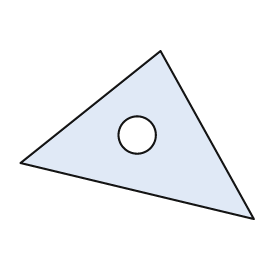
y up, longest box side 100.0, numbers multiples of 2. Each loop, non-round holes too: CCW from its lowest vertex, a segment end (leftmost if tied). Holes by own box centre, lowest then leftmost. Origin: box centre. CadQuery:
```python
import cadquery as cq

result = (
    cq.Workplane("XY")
    .moveTo(50.0, -36.0)
    .lineTo(10.0, 36.0)
    .lineTo(-50.0, -12.0)
    .close()
    .moveTo(0.0, 0.0)
    .circle(8.0)
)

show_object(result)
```